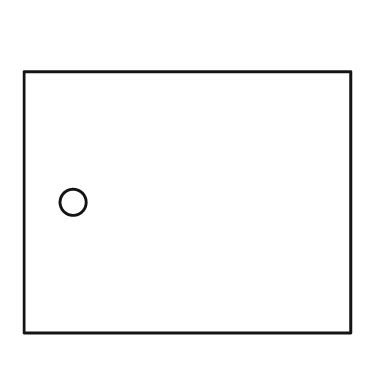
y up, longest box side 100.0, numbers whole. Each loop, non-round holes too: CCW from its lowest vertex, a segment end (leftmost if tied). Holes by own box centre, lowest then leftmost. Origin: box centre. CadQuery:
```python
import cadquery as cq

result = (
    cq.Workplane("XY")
    .moveTo(-50.0, -40.0)
    .lineTo(50.0, -40.0)
    .lineTo(50.0, 40.0)
    .lineTo(-50.0, 40.0)
    .close()
    .moveTo(-35.0, 0.0)
    .circle(4.0)
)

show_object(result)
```